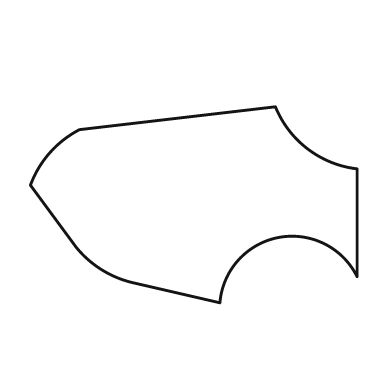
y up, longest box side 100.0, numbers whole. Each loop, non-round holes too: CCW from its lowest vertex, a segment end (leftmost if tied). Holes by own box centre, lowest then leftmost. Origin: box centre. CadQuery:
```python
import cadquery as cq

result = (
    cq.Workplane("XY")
    .moveTo(8.0, -30.0)
    .threePointArc((26.0, -10.0), (50.0, -22.0))
    .lineTo(50.0, 11.0)
    .threePointArc((35.0, 17.0), (25.0, 30.0))
    .lineTo(-35.0, 23.0)
    .threePointArc((-44.0, 16.0), (-50.0, 6.0))
    .lineTo(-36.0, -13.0)
    .threePointArc((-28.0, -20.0), (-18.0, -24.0))
    .close()
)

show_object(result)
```